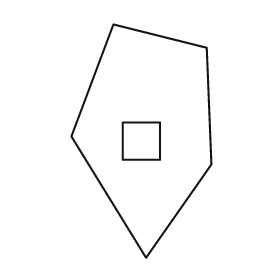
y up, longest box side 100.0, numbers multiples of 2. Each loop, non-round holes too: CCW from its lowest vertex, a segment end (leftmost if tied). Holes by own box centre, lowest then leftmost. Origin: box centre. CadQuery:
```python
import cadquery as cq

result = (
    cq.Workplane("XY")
    .moveTo(2.0, -50.0)
    .lineTo(30.0, -10.0)
    .lineTo(28.0, 40.0)
    .lineTo(-12.0, 50.0)
    .lineTo(-30.0, 2.0)
    .close()
    .moveTo(-8.0, -8.0)
    .lineTo(8.0, -8.0)
    .lineTo(8.0, 8.0)
    .lineTo(-8.0, 8.0)
    .close()
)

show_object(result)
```